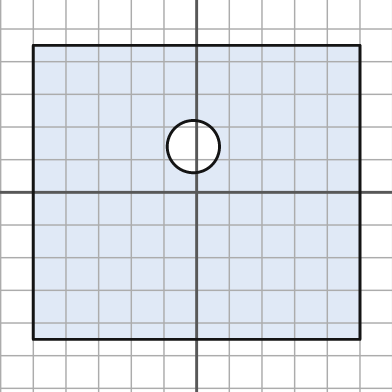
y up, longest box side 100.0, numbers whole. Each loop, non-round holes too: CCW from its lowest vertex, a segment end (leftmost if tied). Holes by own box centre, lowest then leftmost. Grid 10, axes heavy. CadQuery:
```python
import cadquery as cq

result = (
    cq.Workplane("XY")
    .moveTo(-50.0, -45.0)
    .lineTo(50.0, -45.0)
    .lineTo(50.0, 45.0)
    .lineTo(-50.0, 45.0)
    .close()
    .moveTo(-1.0, 14.0)
    .circle(8.0)
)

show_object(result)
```